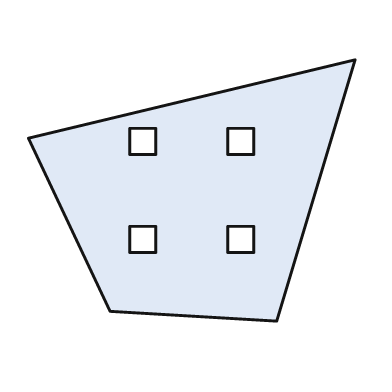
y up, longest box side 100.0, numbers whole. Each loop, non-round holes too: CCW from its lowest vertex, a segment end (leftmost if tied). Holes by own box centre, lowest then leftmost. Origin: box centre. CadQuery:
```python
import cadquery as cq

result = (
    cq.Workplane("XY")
    .moveTo(26.0, -40.0)
    .lineTo(50.0, 40.0)
    .lineTo(-50.0, 16.0)
    .lineTo(-25.0, -37.0)
    .close()
    .moveTo(-19.0, -19.0)
    .lineTo(-11.0, -19.0)
    .lineTo(-11.0, -11.0)
    .lineTo(-19.0, -11.0)
    .close()
    .moveTo(11.0, -19.0)
    .lineTo(19.0, -19.0)
    .lineTo(19.0, -11.0)
    .lineTo(11.0, -11.0)
    .close()
    .moveTo(-19.0, 11.0)
    .lineTo(-11.0, 11.0)
    .lineTo(-11.0, 19.0)
    .lineTo(-19.0, 19.0)
    .close()
    .moveTo(11.0, 11.0)
    .lineTo(19.0, 11.0)
    .lineTo(19.0, 19.0)
    .lineTo(11.0, 19.0)
    .close()
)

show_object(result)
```